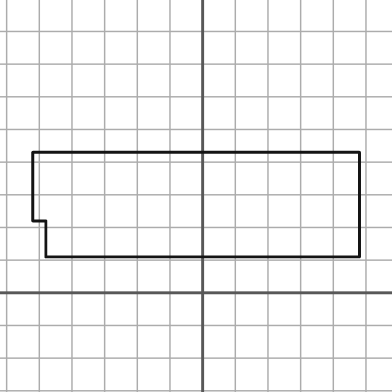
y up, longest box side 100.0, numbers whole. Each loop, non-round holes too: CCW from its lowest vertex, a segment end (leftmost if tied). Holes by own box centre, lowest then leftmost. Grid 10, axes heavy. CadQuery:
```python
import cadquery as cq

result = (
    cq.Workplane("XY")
    .moveTo(-48.0, 11.0)
    .lineTo(48.0, 11.0)
    .lineTo(48.0, 43.0)
    .lineTo(-52.0, 43.0)
    .lineTo(-52.0, 22.0)
    .lineTo(-48.0, 22.0)
    .close()
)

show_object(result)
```